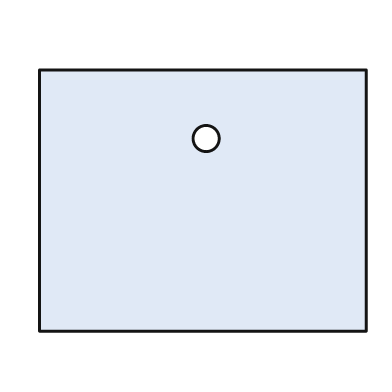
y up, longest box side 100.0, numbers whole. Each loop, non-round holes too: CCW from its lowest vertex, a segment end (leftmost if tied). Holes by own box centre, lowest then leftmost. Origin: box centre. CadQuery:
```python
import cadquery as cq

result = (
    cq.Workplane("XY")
    .moveTo(-50.0, -40.0)
    .lineTo(50.0, -40.0)
    .lineTo(50.0, 40.0)
    .lineTo(-50.0, 40.0)
    .close()
    .moveTo(1.0, 19.0)
    .circle(4.0)
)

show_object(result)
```